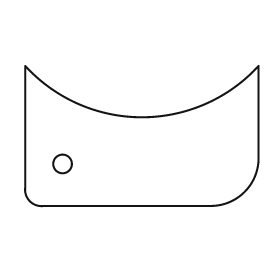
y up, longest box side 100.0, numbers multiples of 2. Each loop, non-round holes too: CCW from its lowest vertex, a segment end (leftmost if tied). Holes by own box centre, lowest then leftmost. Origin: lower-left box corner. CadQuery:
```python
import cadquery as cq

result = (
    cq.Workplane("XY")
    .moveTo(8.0, 0.0)
    .lineTo(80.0, 0.0)
    .threePointArc((94.0, 6.0), (100.0, 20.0))
    .lineTo(100.0, 60.0)
    .threePointArc((50.0, 38.0), (0.0, 60.0))
    .lineTo(0.0, 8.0)
    .threePointArc((2.0, 2.0), (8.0, 0.0))
    .close()
    .moveTo(16.0, 18.0)
    .circle(4.0)
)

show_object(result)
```